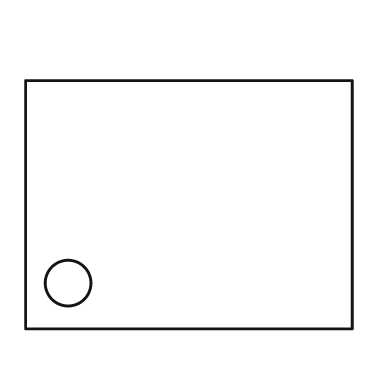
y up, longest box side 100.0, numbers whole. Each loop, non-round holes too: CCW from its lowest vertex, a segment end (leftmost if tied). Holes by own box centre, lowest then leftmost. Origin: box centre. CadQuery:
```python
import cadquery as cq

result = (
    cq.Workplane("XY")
    .moveTo(-50.0, -38.0)
    .lineTo(50.0, -38.0)
    .lineTo(50.0, 38.0)
    .lineTo(-50.0, 38.0)
    .close()
    .moveTo(-37.0, -24.0)
    .circle(7.0)
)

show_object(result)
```